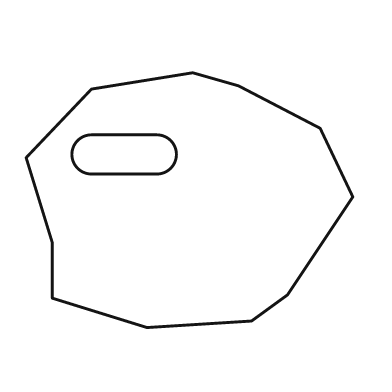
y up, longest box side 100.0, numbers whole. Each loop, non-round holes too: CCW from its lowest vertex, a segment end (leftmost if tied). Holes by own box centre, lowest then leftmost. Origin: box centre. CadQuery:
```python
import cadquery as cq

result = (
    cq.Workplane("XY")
    .moveTo(-13.0, -39.0)
    .lineTo(19.0, -37.0)
    .lineTo(30.0, -29.0)
    .lineTo(50.0, 1.0)
    .lineTo(40.0, 22.0)
    .lineTo(15.0, 35.0)
    .lineTo(1.0, 39.0)
    .lineTo(-30.0, 34.0)
    .lineTo(-50.0, 13.0)
    .lineTo(-42.0, -13.0)
    .lineTo(-42.0, -30.0)
    .close()
    .moveTo(-30.0, 8.0)
    .lineTo(-10.0, 8.0)
    .threePointArc((-4.0, 14.0), (-10.0, 20.0))
    .lineTo(-30.0, 20.0)
    .threePointArc((-36.0, 14.0), (-30.0, 8.0))
    .close()
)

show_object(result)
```